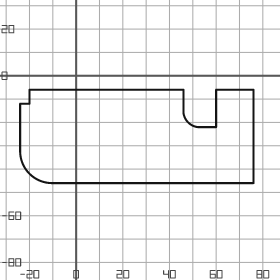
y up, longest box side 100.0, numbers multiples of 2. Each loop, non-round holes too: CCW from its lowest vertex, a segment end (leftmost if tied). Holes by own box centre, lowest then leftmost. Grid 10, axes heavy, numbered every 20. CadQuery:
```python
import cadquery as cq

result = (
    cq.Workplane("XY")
    .moveTo(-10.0, -46.0)
    .lineTo(76.0, -46.0)
    .lineTo(76.0, -6.0)
    .lineTo(60.0, -6.0)
    .lineTo(60.0, -22.0)
    .lineTo(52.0, -22.0)
    .threePointArc((48.0, -20.0), (46.0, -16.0))
    .lineTo(46.0, -6.0)
    .lineTo(-20.0, -6.0)
    .lineTo(-20.0, -12.0)
    .lineTo(-24.0, -12.0)
    .lineTo(-24.0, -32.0)
    .threePointArc((-20.0, -42.0), (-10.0, -46.0))
    .close()
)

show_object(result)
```